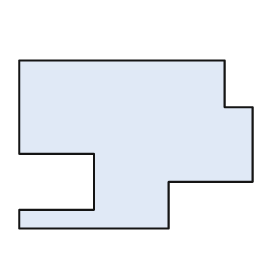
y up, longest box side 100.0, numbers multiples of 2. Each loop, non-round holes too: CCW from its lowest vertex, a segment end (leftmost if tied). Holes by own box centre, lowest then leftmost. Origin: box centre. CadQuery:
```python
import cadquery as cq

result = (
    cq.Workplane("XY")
    .moveTo(-50.0, -36.0)
    .lineTo(14.0, -36.0)
    .lineTo(14.0, -16.0)
    .lineTo(50.0, -16.0)
    .lineTo(50.0, 16.0)
    .lineTo(38.0, 16.0)
    .lineTo(38.0, 36.0)
    .lineTo(-50.0, 36.0)
    .lineTo(-50.0, -4.0)
    .lineTo(-18.0, -4.0)
    .lineTo(-18.0, -28.0)
    .lineTo(-50.0, -28.0)
    .close()
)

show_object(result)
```